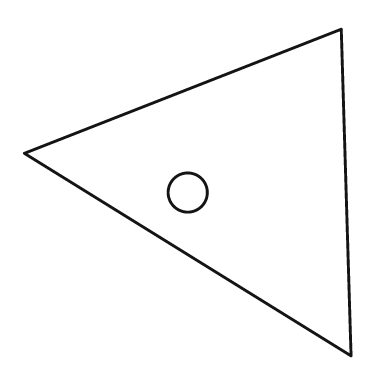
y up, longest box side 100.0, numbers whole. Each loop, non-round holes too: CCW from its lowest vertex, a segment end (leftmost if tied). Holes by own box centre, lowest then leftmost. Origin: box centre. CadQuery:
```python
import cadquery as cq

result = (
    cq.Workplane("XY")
    .moveTo(50.0, -50.0)
    .lineTo(47.0, 50.0)
    .lineTo(-50.0, 12.0)
    .close()
    .moveTo(0.0, 0.0)
    .circle(6.0)
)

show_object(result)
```